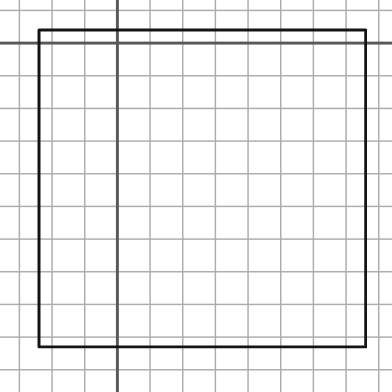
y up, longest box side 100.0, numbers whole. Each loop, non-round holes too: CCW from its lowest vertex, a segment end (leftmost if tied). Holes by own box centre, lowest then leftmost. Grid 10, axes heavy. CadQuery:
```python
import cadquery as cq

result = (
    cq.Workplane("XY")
    .moveTo(-24.0, -93.0)
    .lineTo(76.0, -93.0)
    .lineTo(76.0, 4.0)
    .lineTo(-24.0, 4.0)
    .close()
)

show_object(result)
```